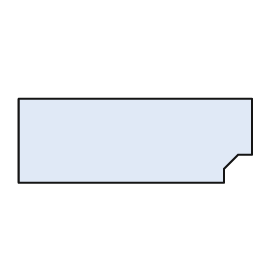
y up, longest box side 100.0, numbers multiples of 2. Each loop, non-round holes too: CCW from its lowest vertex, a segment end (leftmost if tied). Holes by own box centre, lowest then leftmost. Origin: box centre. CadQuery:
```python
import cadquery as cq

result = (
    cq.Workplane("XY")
    .moveTo(-50.0, -18.0)
    .lineTo(38.0, -18.0)
    .lineTo(38.0, -12.0)
    .lineTo(44.0, -6.0)
    .lineTo(50.0, -6.0)
    .lineTo(50.0, 18.0)
    .lineTo(-50.0, 18.0)
    .close()
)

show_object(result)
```